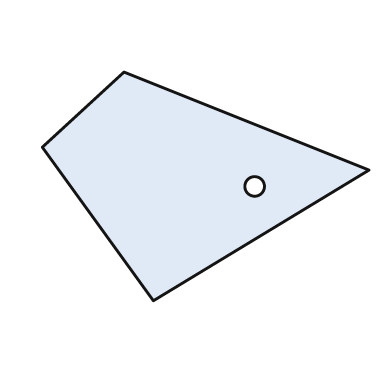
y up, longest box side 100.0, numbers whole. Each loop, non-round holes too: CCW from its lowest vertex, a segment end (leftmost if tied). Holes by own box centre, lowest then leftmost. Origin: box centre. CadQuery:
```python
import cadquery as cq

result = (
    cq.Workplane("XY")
    .moveTo(-16.0, -35.0)
    .lineTo(50.0, 5.0)
    .lineTo(-25.0, 35.0)
    .lineTo(-50.0, 12.0)
    .close()
    .moveTo(15.0, 0.0)
    .circle(3.0)
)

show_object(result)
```